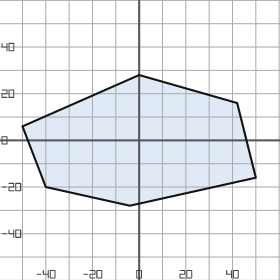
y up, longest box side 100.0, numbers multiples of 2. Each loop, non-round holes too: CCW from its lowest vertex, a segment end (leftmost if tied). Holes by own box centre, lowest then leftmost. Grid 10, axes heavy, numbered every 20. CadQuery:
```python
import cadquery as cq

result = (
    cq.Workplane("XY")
    .moveTo(-4.0, -28.0)
    .lineTo(50.0, -16.0)
    .lineTo(42.0, 16.0)
    .lineTo(0.0, 28.0)
    .lineTo(-50.0, 6.0)
    .lineTo(-40.0, -20.0)
    .close()
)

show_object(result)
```